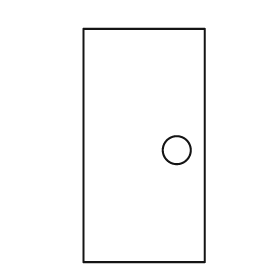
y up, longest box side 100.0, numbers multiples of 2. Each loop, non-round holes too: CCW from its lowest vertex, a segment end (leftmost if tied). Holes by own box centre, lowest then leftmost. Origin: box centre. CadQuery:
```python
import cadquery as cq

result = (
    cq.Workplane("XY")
    .moveTo(-26.0, -50.0)
    .lineTo(26.0, -50.0)
    .lineTo(26.0, 50.0)
    .lineTo(-26.0, 50.0)
    .close()
    .moveTo(14.0, -2.0)
    .circle(6.0)
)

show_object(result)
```